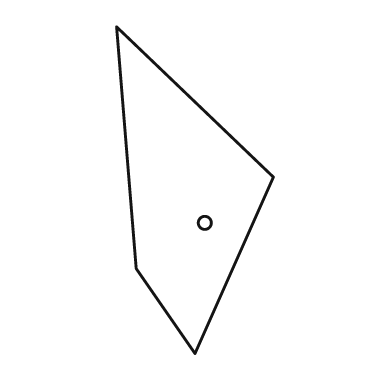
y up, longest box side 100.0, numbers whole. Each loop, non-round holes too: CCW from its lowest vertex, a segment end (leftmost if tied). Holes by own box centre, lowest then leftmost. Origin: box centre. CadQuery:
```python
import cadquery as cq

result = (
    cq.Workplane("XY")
    .moveTo(0.0, -50.0)
    .lineTo(24.0, 4.0)
    .lineTo(-24.0, 50.0)
    .lineTo(-18.0, -24.0)
    .close()
    .moveTo(3.0, -10.0)
    .circle(2.0)
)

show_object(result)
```